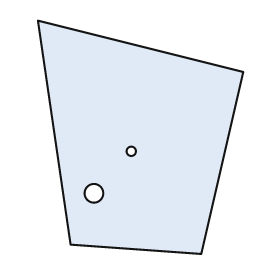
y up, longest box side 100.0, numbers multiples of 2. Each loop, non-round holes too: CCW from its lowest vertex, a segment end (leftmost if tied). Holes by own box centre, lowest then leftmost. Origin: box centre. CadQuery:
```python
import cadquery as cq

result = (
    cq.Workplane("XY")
    .moveTo(26.0, -50.0)
    .lineTo(44.0, 28.0)
    .lineTo(-44.0, 50.0)
    .lineTo(-30.0, -46.0)
    .close()
    .moveTo(-20.0, -24.0)
    .circle(4.0)
    .moveTo(-4.0, -6.0)
    .circle(2.0)
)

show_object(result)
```